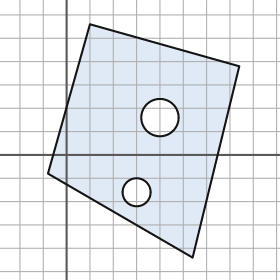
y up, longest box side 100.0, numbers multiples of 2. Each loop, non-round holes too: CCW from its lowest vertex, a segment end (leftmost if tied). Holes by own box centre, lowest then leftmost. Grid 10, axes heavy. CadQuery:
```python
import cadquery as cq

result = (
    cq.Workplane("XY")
    .moveTo(54.0, -44.0)
    .lineTo(74.0, 38.0)
    .lineTo(10.0, 56.0)
    .lineTo(-8.0, -8.0)
    .close()
    .moveTo(30.0, -16.0)
    .circle(6.0)
    .moveTo(40.0, 16.0)
    .circle(8.0)
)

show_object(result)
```